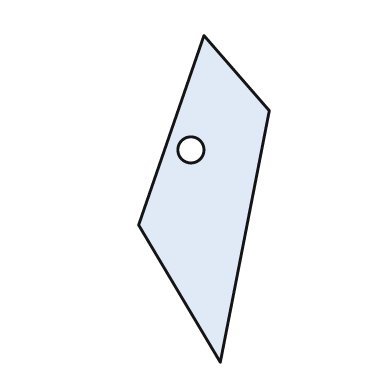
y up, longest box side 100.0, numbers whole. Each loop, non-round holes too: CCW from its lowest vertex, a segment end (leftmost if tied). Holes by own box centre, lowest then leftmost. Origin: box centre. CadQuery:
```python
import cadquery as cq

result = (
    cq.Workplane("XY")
    .moveTo(5.0, -50.0)
    .lineTo(20.0, 27.0)
    .lineTo(0.0, 50.0)
    .lineTo(-20.0, -8.0)
    .close()
    .moveTo(-4.0, 15.0)
    .circle(4.0)
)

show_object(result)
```